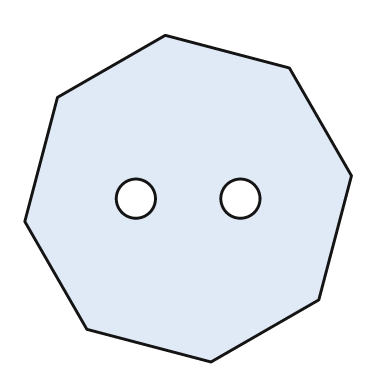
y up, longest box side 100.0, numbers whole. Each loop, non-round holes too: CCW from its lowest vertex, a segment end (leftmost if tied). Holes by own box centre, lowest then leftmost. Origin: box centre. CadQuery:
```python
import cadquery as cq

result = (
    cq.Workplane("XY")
    .moveTo(7.0, -50.0)
    .lineTo(40.0, -31.0)
    .lineTo(50.0, 7.0)
    .lineTo(31.0, 40.0)
    .lineTo(-7.0, 50.0)
    .lineTo(-40.0, 31.0)
    .lineTo(-50.0, -7.0)
    .lineTo(-31.0, -40.0)
    .close()
    .moveTo(-16.0, 0.0)
    .circle(6.0)
    .moveTo(16.0, 0.0)
    .circle(6.0)
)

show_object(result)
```